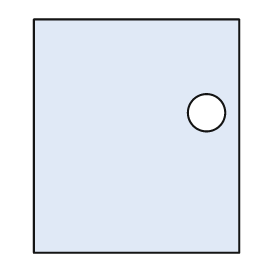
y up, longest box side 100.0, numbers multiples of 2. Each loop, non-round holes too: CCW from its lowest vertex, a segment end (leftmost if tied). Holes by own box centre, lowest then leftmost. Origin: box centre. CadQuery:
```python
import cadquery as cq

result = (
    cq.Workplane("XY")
    .moveTo(-44.0, -50.0)
    .lineTo(44.0, -50.0)
    .lineTo(44.0, 50.0)
    .lineTo(-44.0, 50.0)
    .close()
    .moveTo(30.0, 10.0)
    .circle(8.0)
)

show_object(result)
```